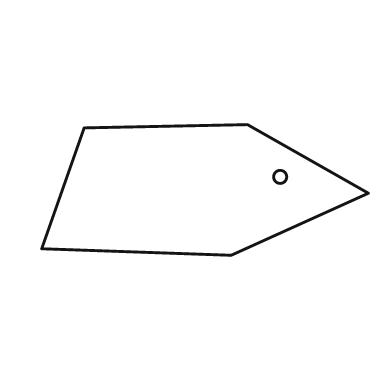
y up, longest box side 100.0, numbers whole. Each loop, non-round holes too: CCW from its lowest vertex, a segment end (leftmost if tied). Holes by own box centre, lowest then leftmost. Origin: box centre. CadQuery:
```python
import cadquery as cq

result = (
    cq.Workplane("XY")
    .moveTo(8.0, -20.0)
    .lineTo(50.0, -1.0)
    .lineTo(13.0, 20.0)
    .lineTo(-37.0, 19.0)
    .lineTo(-50.0, -18.0)
    .close()
    .moveTo(23.0, 4.0)
    .circle(2.0)
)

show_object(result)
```